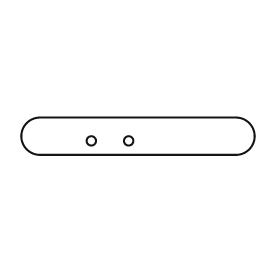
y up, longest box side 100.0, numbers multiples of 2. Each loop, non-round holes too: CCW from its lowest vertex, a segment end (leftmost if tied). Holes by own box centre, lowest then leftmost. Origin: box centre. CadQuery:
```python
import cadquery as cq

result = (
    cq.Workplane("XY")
    .moveTo(-42.0, -8.0)
    .lineTo(42.0, -8.0)
    .threePointArc((50.0, 0.0), (42.0, 8.0))
    .lineTo(-42.0, 8.0)
    .threePointArc((-50.0, 0.0), (-42.0, -8.0))
    .close()
    .moveTo(-20.0, -2.0)
    .circle(2.0)
    .moveTo(-4.0, -2.0)
    .circle(2.0)
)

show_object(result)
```